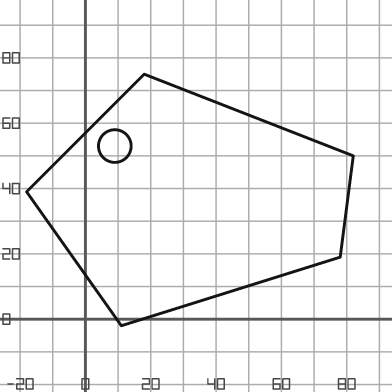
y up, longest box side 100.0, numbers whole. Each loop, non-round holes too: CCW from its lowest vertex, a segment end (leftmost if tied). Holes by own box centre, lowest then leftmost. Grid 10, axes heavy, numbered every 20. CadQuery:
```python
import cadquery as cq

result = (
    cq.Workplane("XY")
    .moveTo(11.0, -2.0)
    .lineTo(78.0, 19.0)
    .lineTo(82.0, 50.0)
    .lineTo(18.0, 75.0)
    .lineTo(-18.0, 39.0)
    .close()
    .moveTo(9.0, 53.0)
    .circle(5.0)
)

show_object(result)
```